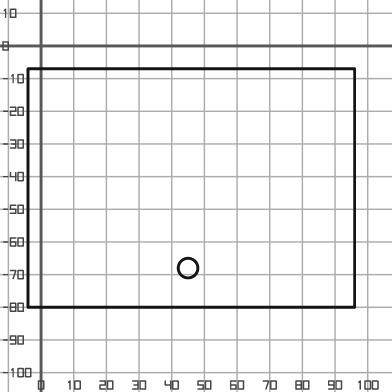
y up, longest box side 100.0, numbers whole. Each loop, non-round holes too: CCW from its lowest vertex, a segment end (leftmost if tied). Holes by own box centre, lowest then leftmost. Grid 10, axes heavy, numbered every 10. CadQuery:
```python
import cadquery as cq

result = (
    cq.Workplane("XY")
    .moveTo(-4.0, -80.0)
    .lineTo(96.0, -80.0)
    .lineTo(96.0, -7.0)
    .lineTo(-4.0, -7.0)
    .close()
    .moveTo(45.0, -68.0)
    .circle(3.0)
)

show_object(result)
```